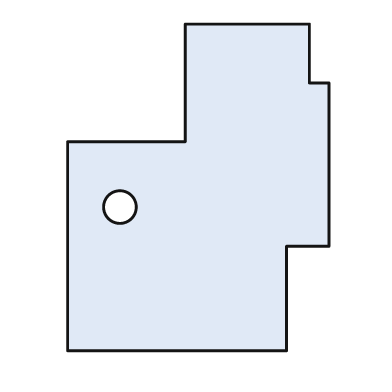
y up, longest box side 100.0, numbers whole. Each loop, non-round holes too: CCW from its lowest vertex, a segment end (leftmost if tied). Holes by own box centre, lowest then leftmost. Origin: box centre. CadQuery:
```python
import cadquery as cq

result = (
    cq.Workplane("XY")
    .moveTo(-40.0, -50.0)
    .lineTo(27.0, -50.0)
    .lineTo(27.0, -18.0)
    .lineTo(40.0, -18.0)
    .lineTo(40.0, 32.0)
    .lineTo(34.0, 32.0)
    .lineTo(34.0, 50.0)
    .lineTo(-4.0, 50.0)
    .lineTo(-4.0, 14.0)
    .lineTo(-40.0, 14.0)
    .close()
    .moveTo(-24.0, -6.0)
    .circle(5.0)
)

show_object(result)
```